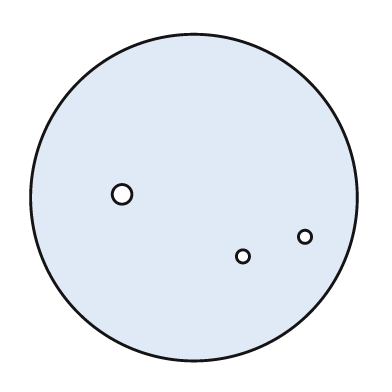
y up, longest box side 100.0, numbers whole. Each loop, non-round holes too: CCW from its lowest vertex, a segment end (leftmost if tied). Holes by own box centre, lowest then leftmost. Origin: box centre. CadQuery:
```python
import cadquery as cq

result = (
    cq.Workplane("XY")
    .moveTo(0.0, 0.0)
    .circle(50.0)
    .moveTo(15.0, -18.0)
    .circle(2.0)
    .moveTo(34.0, -12.0)
    .circle(2.0)
    .moveTo(-22.0, 1.0)
    .circle(3.0)
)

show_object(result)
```